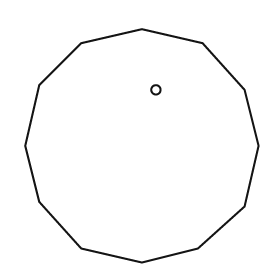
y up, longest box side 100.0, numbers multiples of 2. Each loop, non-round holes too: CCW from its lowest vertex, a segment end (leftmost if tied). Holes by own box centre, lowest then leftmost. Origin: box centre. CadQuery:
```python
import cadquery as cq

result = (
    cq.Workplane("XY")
    .moveTo(0.0, -50.0)
    .lineTo(24.0, -44.0)
    .lineTo(44.0, -26.0)
    .lineTo(50.0, 0.0)
    .lineTo(44.0, 24.0)
    .lineTo(26.0, 44.0)
    .lineTo(0.0, 50.0)
    .lineTo(-26.0, 44.0)
    .lineTo(-44.0, 26.0)
    .lineTo(-50.0, 0.0)
    .lineTo(-44.0, -24.0)
    .lineTo(-26.0, -44.0)
    .close()
    .moveTo(6.0, 24.0)
    .circle(2.0)
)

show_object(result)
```